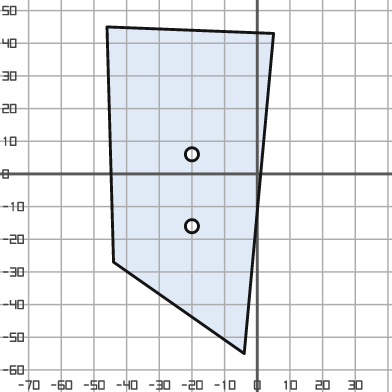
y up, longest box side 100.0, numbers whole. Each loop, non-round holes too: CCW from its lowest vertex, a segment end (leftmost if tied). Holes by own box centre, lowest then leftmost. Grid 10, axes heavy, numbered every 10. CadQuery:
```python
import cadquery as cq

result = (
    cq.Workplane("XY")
    .moveTo(-4.0, -55.0)
    .lineTo(5.0, 43.0)
    .lineTo(-46.0, 45.0)
    .lineTo(-44.0, -27.0)
    .close()
    .moveTo(-20.0, -16.0)
    .circle(2.0)
    .moveTo(-20.0, 6.0)
    .circle(2.0)
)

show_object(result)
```